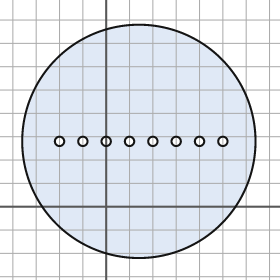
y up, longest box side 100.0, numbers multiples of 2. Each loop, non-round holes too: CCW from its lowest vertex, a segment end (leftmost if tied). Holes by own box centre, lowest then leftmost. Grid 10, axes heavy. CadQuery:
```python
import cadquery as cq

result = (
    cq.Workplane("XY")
    .moveTo(14.0, 28.0)
    .circle(50.0)
    .moveTo(-20.0, 28.0)
    .circle(2.0)
    .moveTo(-10.0, 28.0)
    .circle(2.0)
    .moveTo(0.0, 28.0)
    .circle(2.0)
    .moveTo(10.0, 28.0)
    .circle(2.0)
    .moveTo(20.0, 28.0)
    .circle(2.0)
    .moveTo(30.0, 28.0)
    .circle(2.0)
    .moveTo(40.0, 28.0)
    .circle(2.0)
    .moveTo(50.0, 28.0)
    .circle(2.0)
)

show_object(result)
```